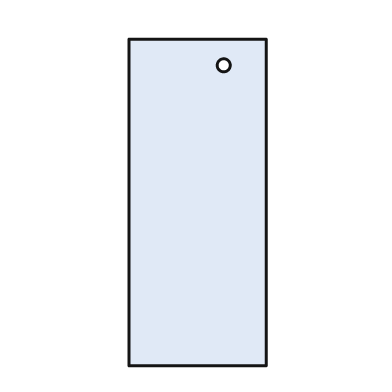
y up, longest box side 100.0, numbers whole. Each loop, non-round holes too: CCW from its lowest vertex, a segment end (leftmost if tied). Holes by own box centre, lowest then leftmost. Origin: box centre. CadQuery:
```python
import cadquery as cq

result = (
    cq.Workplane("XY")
    .moveTo(-21.0, -50.0)
    .lineTo(21.0, -50.0)
    .lineTo(21.0, 50.0)
    .lineTo(-21.0, 50.0)
    .close()
    .moveTo(8.0, 42.0)
    .circle(2.0)
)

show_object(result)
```